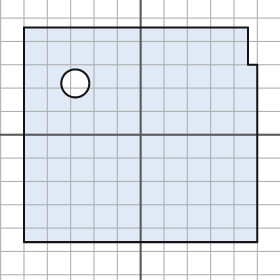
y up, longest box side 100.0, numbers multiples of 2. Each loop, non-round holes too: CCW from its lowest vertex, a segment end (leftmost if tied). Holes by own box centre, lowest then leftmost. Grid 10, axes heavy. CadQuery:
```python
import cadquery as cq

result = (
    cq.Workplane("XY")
    .moveTo(-50.0, -46.0)
    .lineTo(50.0, -46.0)
    .lineTo(50.0, 30.0)
    .lineTo(46.0, 30.0)
    .lineTo(46.0, 46.0)
    .lineTo(-50.0, 46.0)
    .close()
    .moveTo(-28.0, 22.0)
    .circle(6.0)
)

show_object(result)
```